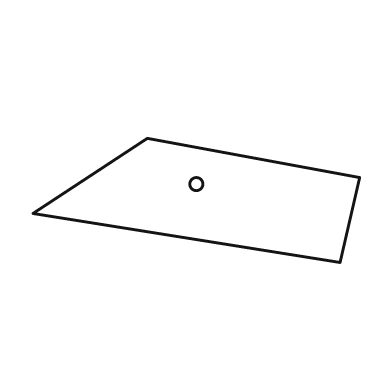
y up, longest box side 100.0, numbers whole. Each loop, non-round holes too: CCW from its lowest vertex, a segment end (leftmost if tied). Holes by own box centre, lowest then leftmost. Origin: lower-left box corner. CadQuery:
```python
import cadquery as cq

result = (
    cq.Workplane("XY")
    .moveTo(94.0, 0.0)
    .lineTo(100.0, 26.0)
    .lineTo(35.0, 38.0)
    .lineTo(0.0, 15.0)
    .close()
    .moveTo(50.0, 24.0)
    .circle(2.0)
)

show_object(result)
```